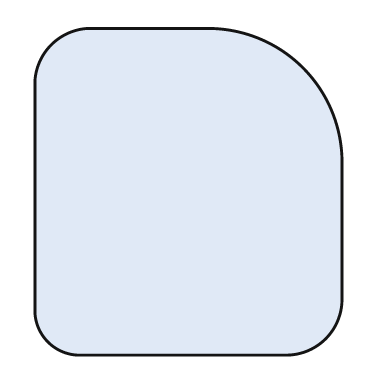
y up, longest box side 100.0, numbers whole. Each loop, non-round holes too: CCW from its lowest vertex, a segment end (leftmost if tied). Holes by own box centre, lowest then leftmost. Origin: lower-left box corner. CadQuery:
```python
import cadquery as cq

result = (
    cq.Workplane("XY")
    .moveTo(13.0, 0.0)
    .lineTo(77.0, 0.0)
    .threePointArc((89.0, 5.0), (94.0, 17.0))
    .lineTo(94.0, 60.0)
    .threePointArc((82.0, 88.0), (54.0, 100.0))
    .lineTo(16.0, 100.0)
    .threePointArc((5.0, 95.0), (0.0, 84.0))
    .lineTo(0.0, 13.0)
    .threePointArc((4.0, 4.0), (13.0, 0.0))
    .close()
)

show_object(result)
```